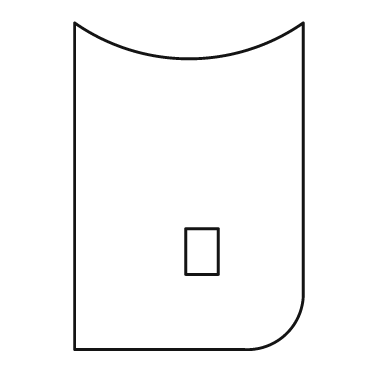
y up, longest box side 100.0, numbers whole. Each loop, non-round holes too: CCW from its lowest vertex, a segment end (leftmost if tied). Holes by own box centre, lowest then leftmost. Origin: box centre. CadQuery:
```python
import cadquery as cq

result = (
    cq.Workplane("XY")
    .moveTo(-35.0, -50.0)
    .lineTo(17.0, -50.0)
    .threePointArc((30.0, -45.0), (35.0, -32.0))
    .lineTo(35.0, 50.0)
    .threePointArc((0.0, 39.0), (-35.0, 50.0))
    .close()
    .moveTo(-1.0, -27.0)
    .lineTo(9.0, -27.0)
    .lineTo(9.0, -13.0)
    .lineTo(-1.0, -13.0)
    .close()
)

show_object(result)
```